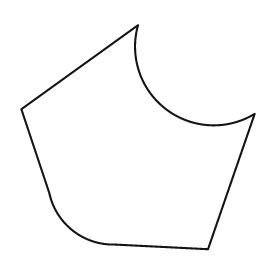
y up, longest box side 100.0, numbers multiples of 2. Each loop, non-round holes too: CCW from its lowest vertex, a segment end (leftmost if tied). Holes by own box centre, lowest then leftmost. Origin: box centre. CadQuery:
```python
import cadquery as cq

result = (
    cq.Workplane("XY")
    .moveTo(30.0, -48.0)
    .lineTo(50.0, 10.0)
    .threePointArc((12.0, 12.0), (0.0, 48.0))
    .lineTo(-50.0, 12.0)
    .lineTo(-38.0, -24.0)
    .threePointArc((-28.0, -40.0), (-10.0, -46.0))
    .close()
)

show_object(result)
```